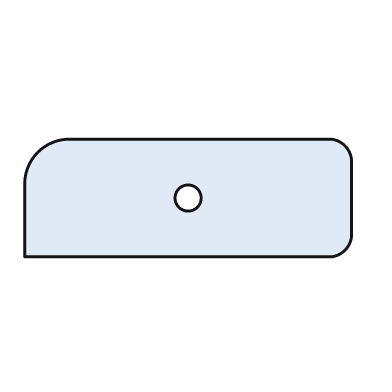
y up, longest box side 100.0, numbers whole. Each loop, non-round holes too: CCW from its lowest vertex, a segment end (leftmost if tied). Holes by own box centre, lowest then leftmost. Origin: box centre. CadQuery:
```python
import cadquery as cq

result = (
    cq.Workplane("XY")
    .moveTo(-50.0, -18.0)
    .lineTo(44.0, -18.0)
    .threePointArc((48.0, -16.0), (50.0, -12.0))
    .lineTo(50.0, 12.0)
    .threePointArc((48.0, 16.0), (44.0, 18.0))
    .lineTo(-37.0, 18.0)
    .threePointArc((-46.0, 14.0), (-50.0, 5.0))
    .close()
    .moveTo(0.0, 0.0)
    .circle(4.0)
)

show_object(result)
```